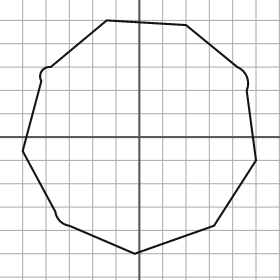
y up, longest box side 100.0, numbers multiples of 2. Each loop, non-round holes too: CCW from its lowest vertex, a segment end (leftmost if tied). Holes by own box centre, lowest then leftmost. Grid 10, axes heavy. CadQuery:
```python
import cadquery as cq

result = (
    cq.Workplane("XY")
    .moveTo(-2.0, -50.0)
    .lineTo(32.0, -38.0)
    .lineTo(50.0, -10.0)
    .lineTo(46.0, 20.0)
    .threePointArc((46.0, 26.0), (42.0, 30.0))
    .lineTo(20.0, 48.0)
    .lineTo(-14.0, 50.0)
    .lineTo(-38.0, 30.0)
    .threePointArc((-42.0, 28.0), (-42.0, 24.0))
    .lineTo(-50.0, -6.0)
    .lineTo(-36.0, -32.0)
    .threePointArc((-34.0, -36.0), (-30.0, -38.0))
    .close()
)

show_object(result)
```